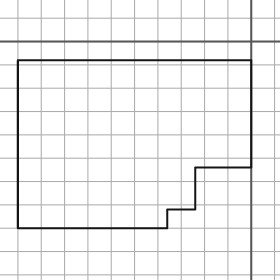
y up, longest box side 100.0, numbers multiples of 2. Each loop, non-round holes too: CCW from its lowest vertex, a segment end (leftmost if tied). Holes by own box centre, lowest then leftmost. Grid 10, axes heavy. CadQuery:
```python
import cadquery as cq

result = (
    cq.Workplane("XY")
    .moveTo(-100.0, -80.0)
    .lineTo(-36.0, -80.0)
    .lineTo(-36.0, -72.0)
    .lineTo(-24.0, -72.0)
    .lineTo(-24.0, -54.0)
    .lineTo(0.0, -54.0)
    .lineTo(0.0, -8.0)
    .lineTo(-100.0, -8.0)
    .close()
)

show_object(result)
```